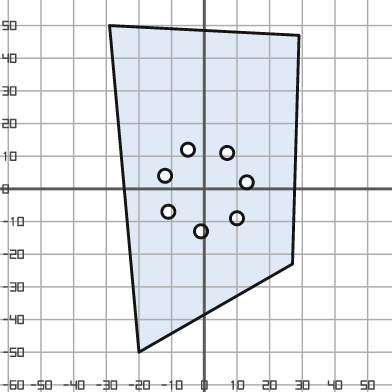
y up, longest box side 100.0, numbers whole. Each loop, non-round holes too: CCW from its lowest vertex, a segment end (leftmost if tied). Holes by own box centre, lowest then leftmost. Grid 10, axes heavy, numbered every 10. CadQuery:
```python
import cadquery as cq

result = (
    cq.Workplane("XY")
    .moveTo(-20.0, -50.0)
    .lineTo(27.0, -23.0)
    .lineTo(29.0, 47.0)
    .lineTo(-29.0, 50.0)
    .close()
    .moveTo(-1.0, -13.0)
    .circle(2.0)
    .moveTo(10.0, -9.0)
    .circle(2.0)
    .moveTo(-11.0, -7.0)
    .circle(2.0)
    .moveTo(13.0, 2.0)
    .circle(2.0)
    .moveTo(-12.0, 4.0)
    .circle(2.0)
    .moveTo(7.0, 11.0)
    .circle(2.0)
    .moveTo(-5.0, 12.0)
    .circle(2.0)
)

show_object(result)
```